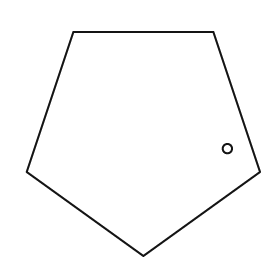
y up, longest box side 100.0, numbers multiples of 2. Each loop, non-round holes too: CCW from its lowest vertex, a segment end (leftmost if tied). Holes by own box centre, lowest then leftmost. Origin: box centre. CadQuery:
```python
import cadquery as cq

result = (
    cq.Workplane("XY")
    .moveTo(0.0, -48.0)
    .lineTo(50.0, -12.0)
    .lineTo(30.0, 48.0)
    .lineTo(-30.0, 48.0)
    .lineTo(-50.0, -12.0)
    .close()
    .moveTo(36.0, -2.0)
    .circle(2.0)
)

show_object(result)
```